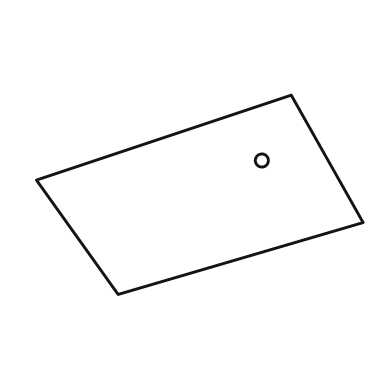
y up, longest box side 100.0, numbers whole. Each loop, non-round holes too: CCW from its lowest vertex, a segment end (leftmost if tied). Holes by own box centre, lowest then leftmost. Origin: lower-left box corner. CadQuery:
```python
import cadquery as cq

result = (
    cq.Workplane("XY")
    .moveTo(25.0, 0.0)
    .lineTo(100.0, 22.0)
    .lineTo(78.0, 61.0)
    .lineTo(0.0, 35.0)
    .close()
    .moveTo(69.0, 41.0)
    .circle(2.0)
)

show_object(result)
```